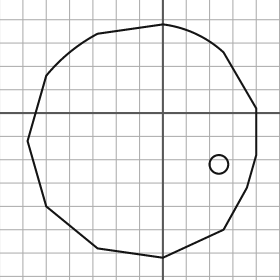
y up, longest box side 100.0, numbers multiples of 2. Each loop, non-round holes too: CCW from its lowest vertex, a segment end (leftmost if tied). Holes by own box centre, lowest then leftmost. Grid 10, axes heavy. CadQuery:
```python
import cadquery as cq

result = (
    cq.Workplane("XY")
    .moveTo(0.0, -62.0)
    .lineTo(26.0, -50.0)
    .lineTo(36.0, -32.0)
    .lineTo(40.0, -18.0)
    .lineTo(40.0, 2.0)
    .lineTo(26.0, 26.0)
    .threePointArc((14.0, 34.0), (0.0, 38.0))
    .lineTo(-28.0, 34.0)
    .threePointArc((-40.0, 26.0), (-50.0, 16.0))
    .lineTo(-58.0, -12.0)
    .lineTo(-50.0, -40.0)
    .lineTo(-28.0, -58.0)
    .close()
    .moveTo(24.0, -22.0)
    .circle(4.0)
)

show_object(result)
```